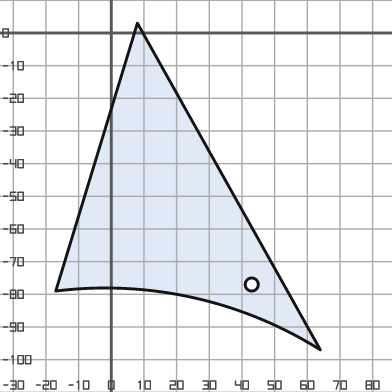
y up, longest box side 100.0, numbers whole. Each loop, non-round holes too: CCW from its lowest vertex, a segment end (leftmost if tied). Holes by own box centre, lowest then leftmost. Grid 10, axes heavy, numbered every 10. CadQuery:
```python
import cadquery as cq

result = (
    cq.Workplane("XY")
    .moveTo(64.0, -97.0)
    .lineTo(8.0, 3.0)
    .lineTo(-17.0, -79.0)
    .threePointArc((25.0, -81.0), (64.0, -97.0))
    .close()
    .moveTo(43.0, -77.0)
    .circle(2.0)
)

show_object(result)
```